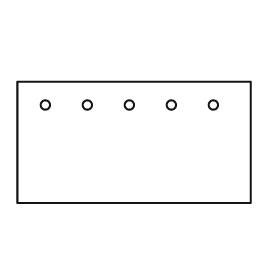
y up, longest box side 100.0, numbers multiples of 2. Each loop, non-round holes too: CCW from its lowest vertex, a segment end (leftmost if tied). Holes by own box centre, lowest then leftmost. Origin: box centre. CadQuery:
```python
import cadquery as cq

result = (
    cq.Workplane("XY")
    .moveTo(-50.0, -26.0)
    .lineTo(50.0, -26.0)
    .lineTo(50.0, 26.0)
    .lineTo(-50.0, 26.0)
    .close()
    .moveTo(-38.0, 16.0)
    .circle(2.0)
    .moveTo(-20.0, 16.0)
    .circle(2.0)
    .moveTo(-2.0, 16.0)
    .circle(2.0)
    .moveTo(16.0, 16.0)
    .circle(2.0)
    .moveTo(34.0, 16.0)
    .circle(2.0)
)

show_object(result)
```